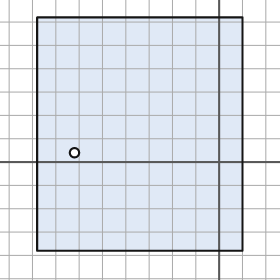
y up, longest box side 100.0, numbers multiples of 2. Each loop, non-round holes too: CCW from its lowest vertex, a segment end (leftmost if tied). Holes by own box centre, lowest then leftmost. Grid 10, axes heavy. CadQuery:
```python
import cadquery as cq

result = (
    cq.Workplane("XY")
    .moveTo(-78.0, -38.0)
    .lineTo(10.0, -38.0)
    .lineTo(10.0, 62.0)
    .lineTo(-78.0, 62.0)
    .close()
    .moveTo(-62.0, 4.0)
    .circle(2.0)
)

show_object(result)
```